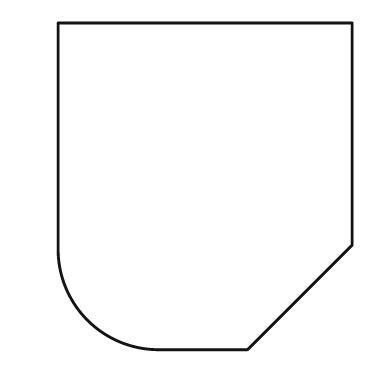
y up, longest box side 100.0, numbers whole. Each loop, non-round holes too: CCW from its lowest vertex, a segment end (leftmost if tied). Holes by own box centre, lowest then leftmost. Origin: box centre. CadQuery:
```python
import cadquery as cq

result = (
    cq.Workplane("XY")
    .moveTo(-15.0, -50.0)
    .lineTo(13.0, -50.0)
    .lineTo(45.0, -18.0)
    .lineTo(45.0, 50.0)
    .lineTo(-45.0, 50.0)
    .lineTo(-45.0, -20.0)
    .threePointArc((-36.0, -41.0), (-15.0, -50.0))
    .close()
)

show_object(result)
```